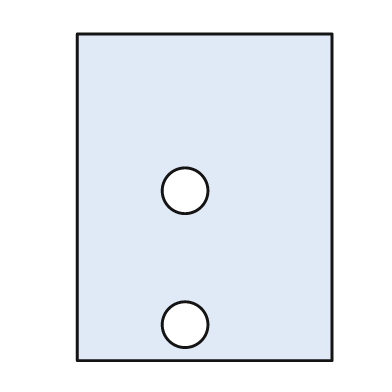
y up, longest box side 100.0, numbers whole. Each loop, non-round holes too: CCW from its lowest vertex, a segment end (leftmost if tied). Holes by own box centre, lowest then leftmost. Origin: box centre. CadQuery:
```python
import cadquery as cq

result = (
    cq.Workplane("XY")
    .moveTo(-39.0, -50.0)
    .lineTo(39.0, -50.0)
    .lineTo(39.0, 50.0)
    .lineTo(-39.0, 50.0)
    .close()
    .moveTo(-6.0, -39.0)
    .circle(7.0)
    .moveTo(-6.0, 2.0)
    .circle(7.0)
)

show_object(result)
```